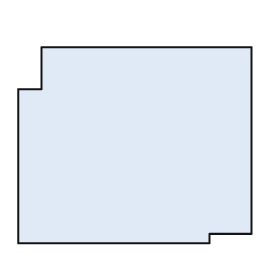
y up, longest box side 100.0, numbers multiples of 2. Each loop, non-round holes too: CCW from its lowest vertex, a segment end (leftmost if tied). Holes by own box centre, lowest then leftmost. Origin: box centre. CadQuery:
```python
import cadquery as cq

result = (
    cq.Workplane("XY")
    .moveTo(-50.0, -42.0)
    .lineTo(32.0, -42.0)
    .lineTo(32.0, -38.0)
    .lineTo(50.0, -38.0)
    .lineTo(50.0, 42.0)
    .lineTo(-40.0, 42.0)
    .lineTo(-40.0, 24.0)
    .lineTo(-50.0, 24.0)
    .close()
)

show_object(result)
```